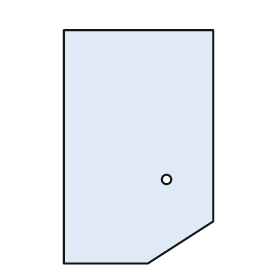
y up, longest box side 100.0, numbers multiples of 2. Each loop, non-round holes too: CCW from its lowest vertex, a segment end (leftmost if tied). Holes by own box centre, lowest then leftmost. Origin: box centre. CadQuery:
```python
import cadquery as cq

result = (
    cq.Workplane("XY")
    .moveTo(-32.0, -50.0)
    .lineTo(4.0, -50.0)
    .lineTo(32.0, -32.0)
    .lineTo(32.0, 50.0)
    .lineTo(-32.0, 50.0)
    .close()
    .moveTo(12.0, -14.0)
    .circle(2.0)
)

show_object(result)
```